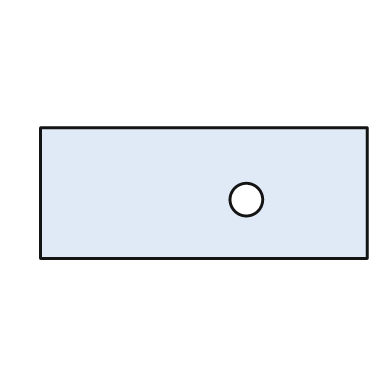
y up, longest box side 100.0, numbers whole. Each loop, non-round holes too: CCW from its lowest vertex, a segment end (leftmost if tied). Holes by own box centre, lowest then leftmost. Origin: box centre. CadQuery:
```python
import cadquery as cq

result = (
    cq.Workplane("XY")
    .moveTo(-50.0, -20.0)
    .lineTo(50.0, -20.0)
    .lineTo(50.0, 20.0)
    .lineTo(-50.0, 20.0)
    .close()
    .moveTo(13.0, -2.0)
    .circle(5.0)
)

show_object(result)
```